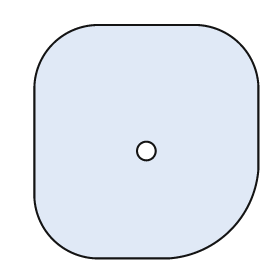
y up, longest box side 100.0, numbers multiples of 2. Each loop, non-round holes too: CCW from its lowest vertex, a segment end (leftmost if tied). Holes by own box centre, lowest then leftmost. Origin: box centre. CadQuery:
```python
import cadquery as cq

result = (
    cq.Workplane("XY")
    .moveTo(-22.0, -50.0)
    .lineTo(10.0, -50.0)
    .threePointArc((36.0, -38.0), (48.0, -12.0))
    .lineTo(48.0, 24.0)
    .threePointArc((40.0, 42.0), (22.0, 50.0))
    .lineTo(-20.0, 50.0)
    .threePointArc((-40.0, 42.0), (-48.0, 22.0))
    .lineTo(-48.0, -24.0)
    .threePointArc((-40.0, -42.0), (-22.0, -50.0))
    .close()
    .moveTo(0.0, -4.0)
    .circle(4.0)
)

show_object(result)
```